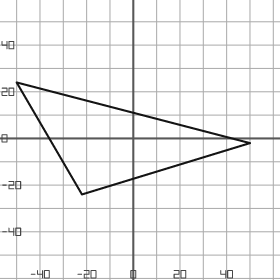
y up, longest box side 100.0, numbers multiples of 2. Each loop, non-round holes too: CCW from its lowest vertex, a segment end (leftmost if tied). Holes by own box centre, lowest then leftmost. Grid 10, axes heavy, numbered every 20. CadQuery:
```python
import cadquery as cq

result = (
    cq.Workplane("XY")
    .moveTo(-22.0, -24.0)
    .lineTo(50.0, -2.0)
    .lineTo(-50.0, 24.0)
    .close()
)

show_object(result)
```